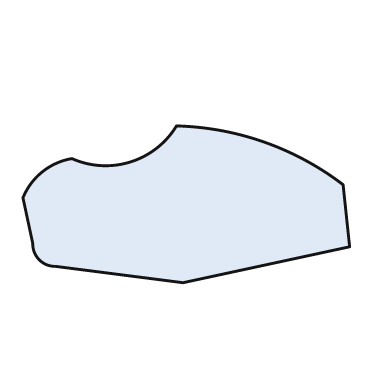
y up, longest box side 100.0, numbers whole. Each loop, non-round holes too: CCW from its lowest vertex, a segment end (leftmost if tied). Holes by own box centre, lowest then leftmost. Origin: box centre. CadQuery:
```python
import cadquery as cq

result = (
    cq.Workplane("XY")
    .moveTo(-1.0, -24.0)
    .lineTo(50.0, -13.0)
    .lineTo(48.0, 6.0)
    .threePointArc((24.0, 19.0), (-3.0, 24.0))
    .threePointArc((-17.0, 13.0), (-35.0, 14.0))
    .threePointArc((-44.0, 10.0), (-50.0, 2.0))
    .lineTo(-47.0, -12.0)
    .threePointArc((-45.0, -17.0), (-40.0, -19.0))
    .close()
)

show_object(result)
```